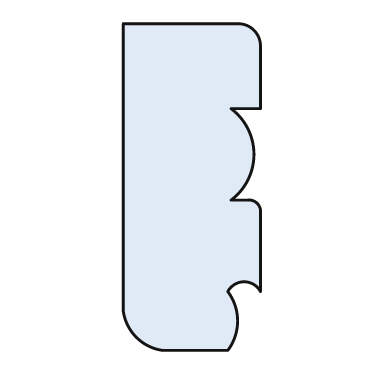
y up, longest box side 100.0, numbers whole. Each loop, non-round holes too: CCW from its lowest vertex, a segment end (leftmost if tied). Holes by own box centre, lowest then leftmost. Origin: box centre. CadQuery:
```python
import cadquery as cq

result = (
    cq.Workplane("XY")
    .moveTo(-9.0, -50.0)
    .lineTo(11.0, -50.0)
    .threePointArc((14.0, -41.0), (11.0, -32.0))
    .threePointArc((16.0, -29.0), (21.0, -32.0))
    .lineTo(21.0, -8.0)
    .threePointArc((20.0, -5.0), (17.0, -4.0))
    .lineTo(12.0, -4.0)
    .threePointArc((19.0, 10.0), (12.0, 24.0))
    .lineTo(21.0, 24.0)
    .lineTo(21.0, 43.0)
    .threePointArc((19.0, 48.0), (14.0, 50.0))
    .lineTo(-21.0, 50.0)
    .lineTo(-21.0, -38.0)
    .threePointArc((-17.0, -46.0), (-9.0, -50.0))
    .close()
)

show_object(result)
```